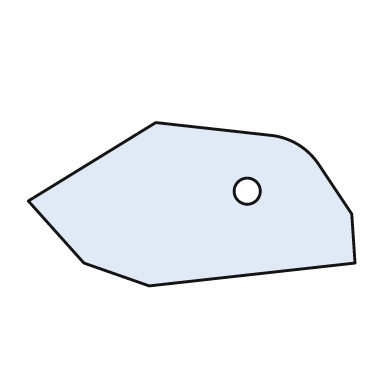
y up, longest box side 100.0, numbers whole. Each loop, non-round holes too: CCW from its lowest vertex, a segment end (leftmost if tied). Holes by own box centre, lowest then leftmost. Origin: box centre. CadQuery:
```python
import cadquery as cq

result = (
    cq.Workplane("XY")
    .moveTo(-13.0, -25.0)
    .lineTo(50.0, -18.0)
    .lineTo(49.0, -3.0)
    .lineTo(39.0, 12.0)
    .threePointArc((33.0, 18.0), (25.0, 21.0))
    .lineTo(-11.0, 25.0)
    .lineTo(-50.0, 1.0)
    .lineTo(-33.0, -18.0)
    .close()
    .moveTo(17.0, 4.0)
    .circle(4.0)
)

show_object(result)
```